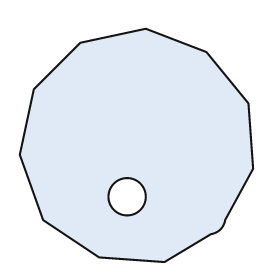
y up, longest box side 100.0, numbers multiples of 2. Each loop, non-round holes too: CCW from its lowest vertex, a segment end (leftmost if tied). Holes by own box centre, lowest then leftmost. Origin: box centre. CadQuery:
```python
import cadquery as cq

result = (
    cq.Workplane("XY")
    .moveTo(12.0, -50.0)
    .lineTo(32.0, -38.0)
    .threePointArc((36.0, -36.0), (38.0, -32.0))
    .lineTo(50.0, -10.0)
    .lineTo(48.0, 18.0)
    .lineTo(30.0, 40.0)
    .lineTo(4.0, 50.0)
    .lineTo(-24.0, 44.0)
    .lineTo(-44.0, 24.0)
    .lineTo(-50.0, -4.0)
    .lineTo(-40.0, -32.0)
    .lineTo(-16.0, -48.0)
    .close()
    .moveTo(-4.0, -22.0)
    .circle(8.0)
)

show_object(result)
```